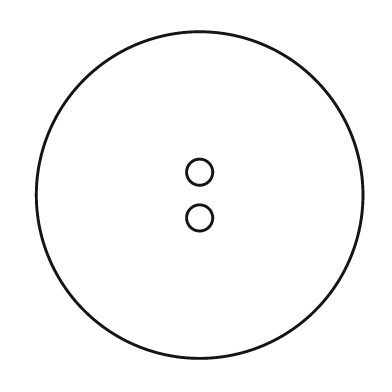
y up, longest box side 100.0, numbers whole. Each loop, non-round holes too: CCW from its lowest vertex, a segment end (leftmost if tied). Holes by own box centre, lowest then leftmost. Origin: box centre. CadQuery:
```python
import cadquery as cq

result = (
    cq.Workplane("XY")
    .moveTo(0.0, 0.0)
    .circle(50.0)
    .moveTo(0.0, -7.0)
    .circle(4.0)
    .moveTo(0.0, 7.0)
    .circle(4.0)
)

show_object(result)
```